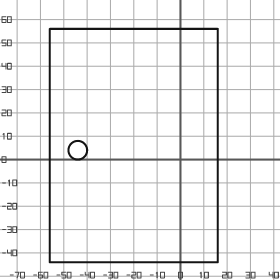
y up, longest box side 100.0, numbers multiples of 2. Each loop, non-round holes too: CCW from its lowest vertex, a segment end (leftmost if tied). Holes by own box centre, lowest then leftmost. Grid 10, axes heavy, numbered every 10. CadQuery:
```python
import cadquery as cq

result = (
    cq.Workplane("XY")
    .moveTo(-56.0, -44.0)
    .lineTo(16.0, -44.0)
    .lineTo(16.0, 56.0)
    .lineTo(-56.0, 56.0)
    .close()
    .moveTo(-44.0, 4.0)
    .circle(4.0)
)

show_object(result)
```